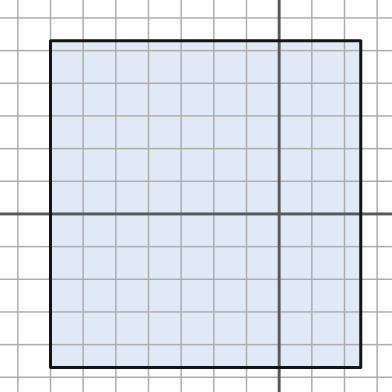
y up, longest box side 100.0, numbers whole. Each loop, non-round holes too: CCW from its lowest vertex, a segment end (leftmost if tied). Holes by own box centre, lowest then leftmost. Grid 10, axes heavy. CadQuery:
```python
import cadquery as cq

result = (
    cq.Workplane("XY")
    .moveTo(-70.0, -47.0)
    .lineTo(25.0, -47.0)
    .lineTo(25.0, 53.0)
    .lineTo(-70.0, 53.0)
    .close()
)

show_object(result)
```